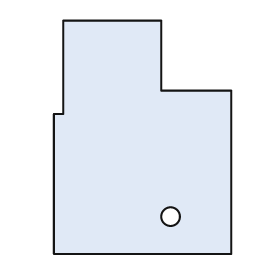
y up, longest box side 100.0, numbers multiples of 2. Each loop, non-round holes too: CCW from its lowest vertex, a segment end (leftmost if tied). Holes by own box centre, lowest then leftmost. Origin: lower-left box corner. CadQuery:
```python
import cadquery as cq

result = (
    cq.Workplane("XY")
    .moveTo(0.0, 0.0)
    .lineTo(76.0, 0.0)
    .lineTo(76.0, 70.0)
    .lineTo(46.0, 70.0)
    .lineTo(46.0, 100.0)
    .lineTo(4.0, 100.0)
    .lineTo(4.0, 60.0)
    .lineTo(0.0, 60.0)
    .close()
    .moveTo(50.0, 16.0)
    .circle(4.0)
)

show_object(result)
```